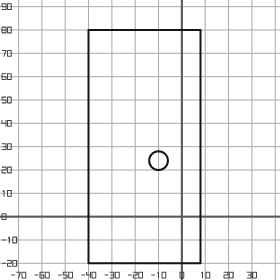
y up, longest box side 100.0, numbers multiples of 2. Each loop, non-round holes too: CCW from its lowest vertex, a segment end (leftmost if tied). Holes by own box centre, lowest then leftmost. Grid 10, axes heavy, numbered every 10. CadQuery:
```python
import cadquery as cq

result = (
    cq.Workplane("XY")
    .moveTo(-40.0, -20.0)
    .lineTo(8.0, -20.0)
    .lineTo(8.0, 80.0)
    .lineTo(-40.0, 80.0)
    .close()
    .moveTo(-10.0, 24.0)
    .circle(4.0)
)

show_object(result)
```